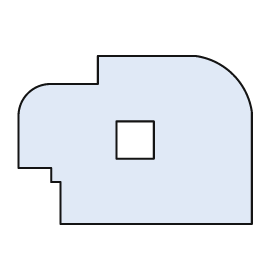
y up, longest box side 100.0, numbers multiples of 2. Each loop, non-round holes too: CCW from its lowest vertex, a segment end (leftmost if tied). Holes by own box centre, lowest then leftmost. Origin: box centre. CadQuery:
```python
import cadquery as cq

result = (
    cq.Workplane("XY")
    .moveTo(-32.0, -36.0)
    .lineTo(50.0, -36.0)
    .lineTo(50.0, 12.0)
    .threePointArc((42.0, 28.0), (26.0, 36.0))
    .lineTo(-16.0, 36.0)
    .lineTo(-16.0, 24.0)
    .lineTo(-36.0, 24.0)
    .threePointArc((-46.0, 20.0), (-50.0, 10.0))
    .lineTo(-50.0, -12.0)
    .lineTo(-36.0, -12.0)
    .lineTo(-36.0, -18.0)
    .lineTo(-32.0, -18.0)
    .close()
    .moveTo(-8.0, -8.0)
    .lineTo(8.0, -8.0)
    .lineTo(8.0, 8.0)
    .lineTo(-8.0, 8.0)
    .close()
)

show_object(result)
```